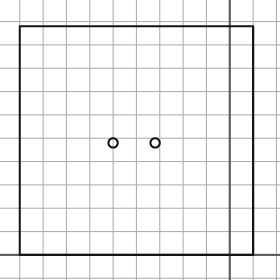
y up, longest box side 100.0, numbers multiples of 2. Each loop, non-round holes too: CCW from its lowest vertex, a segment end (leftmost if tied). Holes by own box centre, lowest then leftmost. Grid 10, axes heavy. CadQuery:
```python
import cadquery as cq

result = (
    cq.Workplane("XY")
    .moveTo(-90.0, 0.0)
    .lineTo(10.0, 0.0)
    .lineTo(10.0, 98.0)
    .lineTo(-90.0, 98.0)
    .close()
    .moveTo(-50.0, 48.0)
    .circle(2.0)
    .moveTo(-32.0, 48.0)
    .circle(2.0)
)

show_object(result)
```